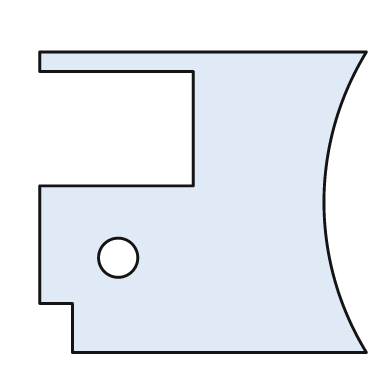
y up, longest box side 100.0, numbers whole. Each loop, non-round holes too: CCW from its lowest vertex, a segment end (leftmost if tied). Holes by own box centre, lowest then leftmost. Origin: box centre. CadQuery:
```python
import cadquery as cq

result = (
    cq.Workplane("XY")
    .moveTo(-40.0, -46.0)
    .lineTo(50.0, -46.0)
    .threePointArc((37.0, 0.0), (50.0, 46.0))
    .lineTo(-50.0, 46.0)
    .lineTo(-50.0, 40.0)
    .lineTo(-3.0, 40.0)
    .lineTo(-3.0, 5.0)
    .lineTo(-50.0, 5.0)
    .lineTo(-50.0, -31.0)
    .lineTo(-40.0, -31.0)
    .close()
    .moveTo(-26.0, -17.0)
    .circle(6.0)
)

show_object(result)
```